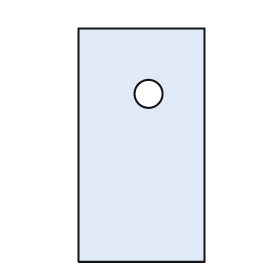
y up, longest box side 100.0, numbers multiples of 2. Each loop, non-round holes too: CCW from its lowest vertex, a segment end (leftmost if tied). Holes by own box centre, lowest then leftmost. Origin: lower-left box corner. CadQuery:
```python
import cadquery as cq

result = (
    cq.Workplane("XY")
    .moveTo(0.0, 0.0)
    .lineTo(54.0, 0.0)
    .lineTo(54.0, 100.0)
    .lineTo(0.0, 100.0)
    .close()
    .moveTo(30.0, 72.0)
    .circle(6.0)
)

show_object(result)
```